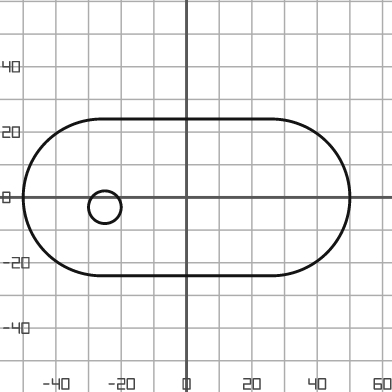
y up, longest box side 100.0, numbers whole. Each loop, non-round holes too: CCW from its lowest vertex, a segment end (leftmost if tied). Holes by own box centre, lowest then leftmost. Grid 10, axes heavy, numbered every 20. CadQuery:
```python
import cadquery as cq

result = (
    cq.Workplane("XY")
    .moveTo(-26.0, -24.0)
    .lineTo(26.0, -24.0)
    .threePointArc((50.0, 0.0), (26.0, 24.0))
    .lineTo(-26.0, 24.0)
    .threePointArc((-50.0, 0.0), (-26.0, -24.0))
    .close()
    .moveTo(-25.0, -3.0)
    .circle(5.0)
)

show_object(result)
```